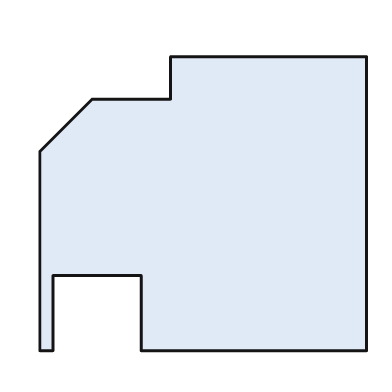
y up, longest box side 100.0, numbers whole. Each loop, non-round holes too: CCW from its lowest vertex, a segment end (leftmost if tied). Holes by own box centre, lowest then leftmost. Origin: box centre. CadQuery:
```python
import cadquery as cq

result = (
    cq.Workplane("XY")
    .moveTo(-50.0, -45.0)
    .lineTo(-46.0, -45.0)
    .lineTo(-46.0, -22.0)
    .lineTo(-19.0, -22.0)
    .lineTo(-19.0, -45.0)
    .lineTo(50.0, -45.0)
    .lineTo(50.0, 45.0)
    .lineTo(-10.0, 45.0)
    .lineTo(-10.0, 32.0)
    .lineTo(-34.0, 32.0)
    .lineTo(-50.0, 16.0)
    .close()
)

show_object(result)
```